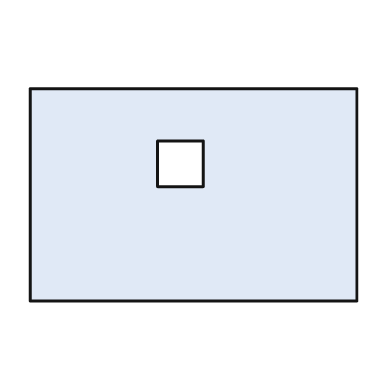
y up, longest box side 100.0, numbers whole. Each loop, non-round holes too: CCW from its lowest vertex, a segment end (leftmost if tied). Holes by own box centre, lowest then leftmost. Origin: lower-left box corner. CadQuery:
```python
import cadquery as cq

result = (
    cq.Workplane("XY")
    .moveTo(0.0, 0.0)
    .lineTo(100.0, 0.0)
    .lineTo(100.0, 65.0)
    .lineTo(0.0, 65.0)
    .close()
    .moveTo(39.0, 35.0)
    .lineTo(53.0, 35.0)
    .lineTo(53.0, 49.0)
    .lineTo(39.0, 49.0)
    .close()
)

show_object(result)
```